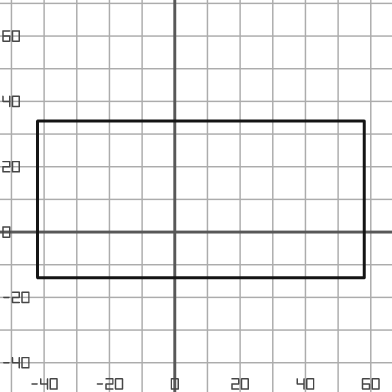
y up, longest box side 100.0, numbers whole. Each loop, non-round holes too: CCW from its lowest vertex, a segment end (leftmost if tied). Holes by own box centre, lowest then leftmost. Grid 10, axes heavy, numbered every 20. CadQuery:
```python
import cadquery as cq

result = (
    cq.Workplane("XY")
    .moveTo(-42.0, -14.0)
    .lineTo(58.0, -14.0)
    .lineTo(58.0, 34.0)
    .lineTo(-42.0, 34.0)
    .close()
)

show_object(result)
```